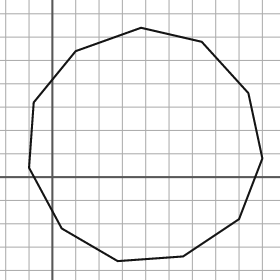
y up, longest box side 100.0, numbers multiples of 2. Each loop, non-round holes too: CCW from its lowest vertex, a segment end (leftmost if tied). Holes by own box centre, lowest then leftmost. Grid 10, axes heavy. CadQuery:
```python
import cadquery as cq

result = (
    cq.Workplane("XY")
    .moveTo(28.0, -36.0)
    .lineTo(56.0, -34.0)
    .lineTo(80.0, -18.0)
    .lineTo(90.0, 8.0)
    .lineTo(84.0, 36.0)
    .lineTo(64.0, 58.0)
    .lineTo(38.0, 64.0)
    .lineTo(10.0, 54.0)
    .lineTo(-8.0, 32.0)
    .lineTo(-10.0, 4.0)
    .lineTo(4.0, -22.0)
    .close()
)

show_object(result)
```